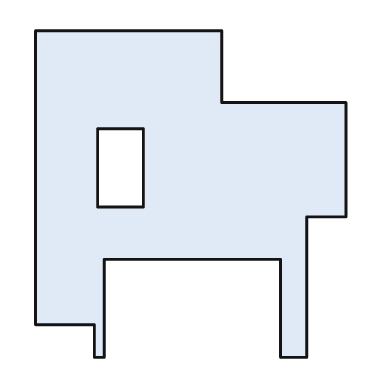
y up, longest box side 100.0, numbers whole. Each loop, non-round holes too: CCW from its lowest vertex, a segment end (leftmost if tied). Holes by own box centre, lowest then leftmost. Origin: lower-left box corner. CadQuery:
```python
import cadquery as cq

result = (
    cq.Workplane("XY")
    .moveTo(18.0, 0.0)
    .lineTo(21.0, 0.0)
    .lineTo(21.0, 30.0)
    .lineTo(75.0, 30.0)
    .lineTo(75.0, 0.0)
    .lineTo(83.0, 0.0)
    .lineTo(83.0, 43.0)
    .lineTo(95.0, 43.0)
    .lineTo(95.0, 78.0)
    .lineTo(57.0, 78.0)
    .lineTo(57.0, 100.0)
    .lineTo(0.0, 100.0)
    .lineTo(0.0, 10.0)
    .lineTo(18.0, 10.0)
    .close()
    .moveTo(19.0, 46.0)
    .lineTo(33.0, 46.0)
    .lineTo(33.0, 70.0)
    .lineTo(19.0, 70.0)
    .close()
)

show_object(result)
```